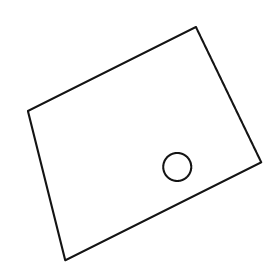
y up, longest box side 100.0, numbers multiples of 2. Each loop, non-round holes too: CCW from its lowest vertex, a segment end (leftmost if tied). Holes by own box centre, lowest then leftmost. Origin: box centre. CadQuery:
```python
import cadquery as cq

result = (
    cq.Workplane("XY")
    .moveTo(-34.0, -50.0)
    .lineTo(50.0, -8.0)
    .lineTo(22.0, 50.0)
    .lineTo(-50.0, 14.0)
    .close()
    .moveTo(14.0, -10.0)
    .circle(6.0)
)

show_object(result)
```